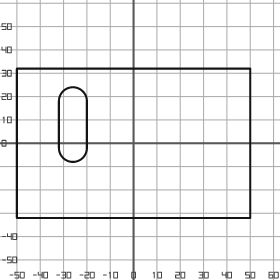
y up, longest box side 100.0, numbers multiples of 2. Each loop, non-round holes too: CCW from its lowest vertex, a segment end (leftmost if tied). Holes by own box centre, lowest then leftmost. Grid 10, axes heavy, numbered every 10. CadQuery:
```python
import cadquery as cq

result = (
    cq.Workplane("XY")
    .moveTo(-50.0, -32.0)
    .lineTo(50.0, -32.0)
    .lineTo(50.0, 32.0)
    .lineTo(-50.0, 32.0)
    .close()
    .moveTo(-32.0, -2.0)
    .threePointArc((-26.0, -8.0), (-20.0, -2.0))
    .lineTo(-20.0, 18.0)
    .threePointArc((-26.0, 24.0), (-32.0, 18.0))
    .close()
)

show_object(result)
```